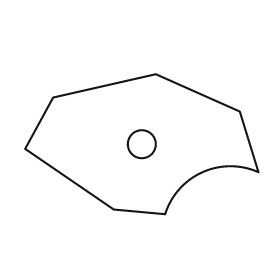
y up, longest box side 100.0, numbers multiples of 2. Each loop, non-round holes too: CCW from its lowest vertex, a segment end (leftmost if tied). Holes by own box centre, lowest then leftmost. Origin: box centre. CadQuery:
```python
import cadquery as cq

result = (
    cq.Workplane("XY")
    .moveTo(10.0, -30.0)
    .threePointArc((26.0, -12.0), (50.0, -12.0))
    .lineTo(42.0, 14.0)
    .lineTo(6.0, 30.0)
    .lineTo(-38.0, 20.0)
    .lineTo(-50.0, -2.0)
    .lineTo(-12.0, -28.0)
    .close()
    .moveTo(0.0, 0.0)
    .circle(6.0)
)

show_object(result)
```